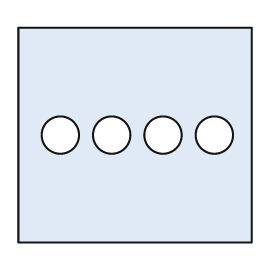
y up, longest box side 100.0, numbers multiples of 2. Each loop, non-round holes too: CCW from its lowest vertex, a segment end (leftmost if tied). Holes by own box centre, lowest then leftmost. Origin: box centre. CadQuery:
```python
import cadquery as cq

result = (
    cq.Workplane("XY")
    .moveTo(-50.0, -46.0)
    .lineTo(50.0, -46.0)
    .lineTo(50.0, 46.0)
    .lineTo(-50.0, 46.0)
    .close()
    .moveTo(-32.0, 0.0)
    .circle(8.0)
    .moveTo(-10.0, 0.0)
    .circle(8.0)
    .moveTo(12.0, 0.0)
    .circle(8.0)
    .moveTo(34.0, 0.0)
    .circle(8.0)
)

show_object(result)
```